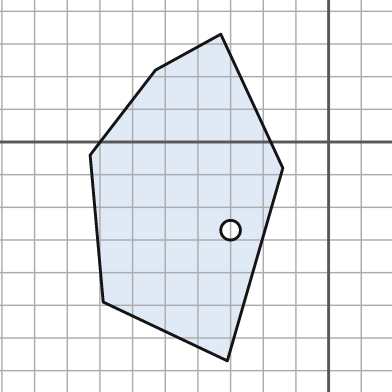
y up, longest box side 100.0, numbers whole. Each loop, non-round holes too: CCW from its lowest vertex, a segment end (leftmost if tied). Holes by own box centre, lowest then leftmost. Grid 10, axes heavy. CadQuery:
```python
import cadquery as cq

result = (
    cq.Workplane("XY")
    .moveTo(-31.0, -67.0)
    .lineTo(-14.0, -8.0)
    .lineTo(-33.0, 33.0)
    .lineTo(-53.0, 22.0)
    .lineTo(-73.0, -4.0)
    .lineTo(-69.0, -49.0)
    .close()
    .moveTo(-30.0, -27.0)
    .circle(3.0)
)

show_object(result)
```